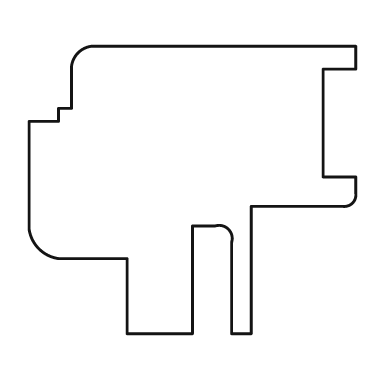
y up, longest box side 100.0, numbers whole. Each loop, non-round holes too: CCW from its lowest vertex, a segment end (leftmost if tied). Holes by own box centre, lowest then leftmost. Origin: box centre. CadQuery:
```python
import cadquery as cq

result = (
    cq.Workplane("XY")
    .moveTo(-20.0, -44.0)
    .lineTo(0.0, -44.0)
    .lineTo(0.0, -11.0)
    .lineTo(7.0, -11.0)
    .threePointArc((11.0, -12.0), (12.0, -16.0))
    .lineTo(12.0, -44.0)
    .lineTo(18.0, -44.0)
    .lineTo(18.0, -5.0)
    .lineTo(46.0, -5.0)
    .threePointArc((49.0, -4.0), (50.0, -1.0))
    .lineTo(50.0, 4.0)
    .lineTo(40.0, 4.0)
    .lineTo(40.0, 37.0)
    .lineTo(50.0, 37.0)
    .lineTo(50.0, 44.0)
    .lineTo(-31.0, 44.0)
    .threePointArc((-35.0, 42.0), (-37.0, 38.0))
    .lineTo(-37.0, 25.0)
    .lineTo(-41.0, 25.0)
    .lineTo(-41.0, 21.0)
    .lineTo(-50.0, 21.0)
    .lineTo(-50.0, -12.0)
    .threePointArc((-47.0, -18.0), (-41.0, -21.0))
    .lineTo(-20.0, -21.0)
    .close()
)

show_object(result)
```